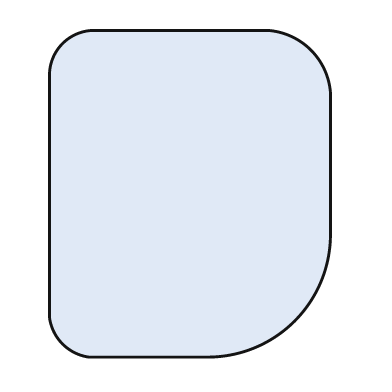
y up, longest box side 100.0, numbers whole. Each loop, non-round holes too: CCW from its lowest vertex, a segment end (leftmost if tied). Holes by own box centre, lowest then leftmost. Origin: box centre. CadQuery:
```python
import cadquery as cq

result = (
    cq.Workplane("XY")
    .moveTo(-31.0, -50.0)
    .lineTo(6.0, -50.0)
    .threePointArc((32.0, -39.0), (43.0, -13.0))
    .lineTo(43.0, 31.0)
    .threePointArc((37.0, 44.0), (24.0, 50.0))
    .lineTo(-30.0, 50.0)
    .threePointArc((-39.0, 46.0), (-43.0, 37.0))
    .lineTo(-43.0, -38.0)
    .threePointArc((-39.0, -46.0), (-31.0, -50.0))
    .close()
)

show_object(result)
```